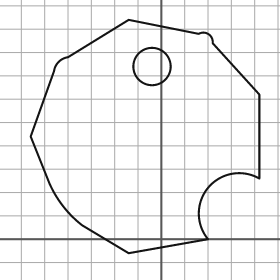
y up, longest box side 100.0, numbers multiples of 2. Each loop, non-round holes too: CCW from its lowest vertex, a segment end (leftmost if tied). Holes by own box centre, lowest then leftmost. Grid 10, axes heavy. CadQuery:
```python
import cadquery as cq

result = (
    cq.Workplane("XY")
    .moveTo(-14.0, -6.0)
    .lineTo(20.0, 0.0)
    .threePointArc((20.0, 22.0), (42.0, 26.0))
    .lineTo(42.0, 62.0)
    .lineTo(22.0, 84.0)
    .threePointArc((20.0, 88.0), (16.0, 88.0))
    .lineTo(-14.0, 94.0)
    .lineTo(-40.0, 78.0)
    .threePointArc((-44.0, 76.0), (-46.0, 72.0))
    .lineTo(-56.0, 44.0)
    .lineTo(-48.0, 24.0)
    .threePointArc((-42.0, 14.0), (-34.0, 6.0))
    .close()
    .moveTo(-4.0, 74.0)
    .circle(8.0)
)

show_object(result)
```